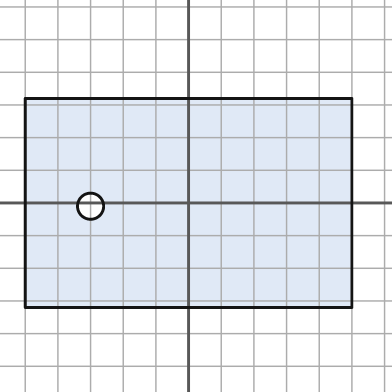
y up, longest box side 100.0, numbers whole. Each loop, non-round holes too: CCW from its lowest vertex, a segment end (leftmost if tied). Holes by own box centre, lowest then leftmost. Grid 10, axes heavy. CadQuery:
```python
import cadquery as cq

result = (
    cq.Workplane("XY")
    .moveTo(-50.0, -32.0)
    .lineTo(50.0, -32.0)
    .lineTo(50.0, 32.0)
    .lineTo(-50.0, 32.0)
    .close()
    .moveTo(-30.0, -1.0)
    .circle(4.0)
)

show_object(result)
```